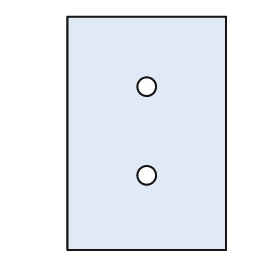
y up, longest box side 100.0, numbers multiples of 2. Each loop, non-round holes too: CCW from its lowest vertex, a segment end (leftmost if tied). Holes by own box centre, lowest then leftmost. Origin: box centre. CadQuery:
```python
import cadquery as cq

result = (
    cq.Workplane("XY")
    .moveTo(-34.0, -50.0)
    .lineTo(34.0, -50.0)
    .lineTo(34.0, 50.0)
    .lineTo(-34.0, 50.0)
    .close()
    .moveTo(0.0, -18.0)
    .circle(4.0)
    .moveTo(0.0, 20.0)
    .circle(4.0)
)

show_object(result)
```